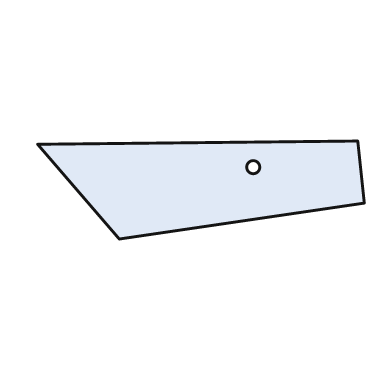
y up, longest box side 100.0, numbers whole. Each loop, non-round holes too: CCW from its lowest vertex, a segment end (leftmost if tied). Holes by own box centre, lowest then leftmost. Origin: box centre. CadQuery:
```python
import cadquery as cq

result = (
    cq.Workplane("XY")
    .moveTo(-25.0, -15.0)
    .lineTo(50.0, -4.0)
    .lineTo(48.0, 15.0)
    .lineTo(-50.0, 14.0)
    .close()
    .moveTo(16.0, 7.0)
    .circle(2.0)
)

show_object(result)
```